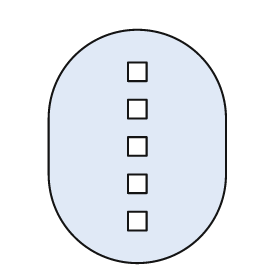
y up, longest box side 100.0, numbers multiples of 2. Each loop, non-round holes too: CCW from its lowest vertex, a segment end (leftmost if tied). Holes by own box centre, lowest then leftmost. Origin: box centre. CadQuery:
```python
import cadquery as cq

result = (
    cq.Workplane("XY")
    .moveTo(-38.0, -12.0)
    .threePointArc((0.0, -50.0), (38.0, -12.0))
    .lineTo(38.0, 12.0)
    .threePointArc((0.0, 50.0), (-38.0, 12.0))
    .close()
    .moveTo(-4.0, -36.0)
    .lineTo(4.0, -36.0)
    .lineTo(4.0, -28.0)
    .lineTo(-4.0, -28.0)
    .close()
    .moveTo(-4.0, -20.0)
    .lineTo(4.0, -20.0)
    .lineTo(4.0, -12.0)
    .lineTo(-4.0, -12.0)
    .close()
    .moveTo(-4.0, -4.0)
    .lineTo(4.0, -4.0)
    .lineTo(4.0, 4.0)
    .lineTo(-4.0, 4.0)
    .close()
    .moveTo(-4.0, 12.0)
    .lineTo(4.0, 12.0)
    .lineTo(4.0, 20.0)
    .lineTo(-4.0, 20.0)
    .close()
    .moveTo(-4.0, 28.0)
    .lineTo(4.0, 28.0)
    .lineTo(4.0, 36.0)
    .lineTo(-4.0, 36.0)
    .close()
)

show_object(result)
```